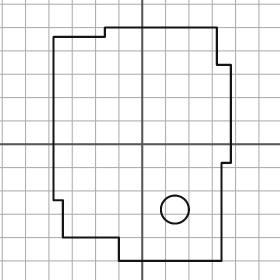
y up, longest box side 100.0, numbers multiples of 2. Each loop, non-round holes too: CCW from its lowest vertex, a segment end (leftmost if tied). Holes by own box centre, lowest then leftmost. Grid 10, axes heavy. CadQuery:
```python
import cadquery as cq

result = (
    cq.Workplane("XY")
    .moveTo(-10.0, -50.0)
    .lineTo(34.0, -50.0)
    .lineTo(34.0, -8.0)
    .lineTo(38.0, -8.0)
    .lineTo(38.0, 34.0)
    .lineTo(32.0, 34.0)
    .lineTo(32.0, 50.0)
    .lineTo(-16.0, 50.0)
    .lineTo(-16.0, 46.0)
    .lineTo(-38.0, 46.0)
    .lineTo(-38.0, -24.0)
    .lineTo(-34.0, -24.0)
    .lineTo(-34.0, -40.0)
    .lineTo(-10.0, -40.0)
    .close()
    .moveTo(14.0, -28.0)
    .circle(6.0)
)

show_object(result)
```